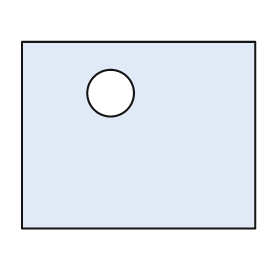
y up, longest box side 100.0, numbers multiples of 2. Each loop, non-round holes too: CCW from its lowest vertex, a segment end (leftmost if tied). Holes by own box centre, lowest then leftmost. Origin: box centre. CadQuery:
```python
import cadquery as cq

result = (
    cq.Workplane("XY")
    .moveTo(-50.0, -40.0)
    .lineTo(50.0, -40.0)
    .lineTo(50.0, 40.0)
    .lineTo(-50.0, 40.0)
    .close()
    .moveTo(-12.0, 18.0)
    .circle(10.0)
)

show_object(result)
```